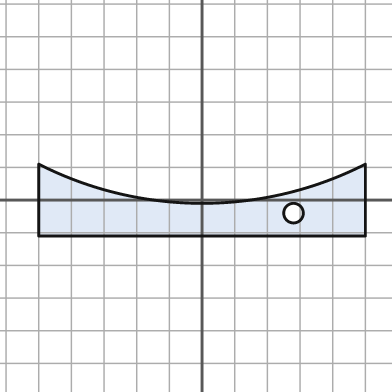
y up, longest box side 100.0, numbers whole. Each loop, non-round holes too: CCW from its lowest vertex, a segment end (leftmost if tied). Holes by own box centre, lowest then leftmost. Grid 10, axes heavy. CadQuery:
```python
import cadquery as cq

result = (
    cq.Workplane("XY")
    .moveTo(-50.0, -11.0)
    .lineTo(50.0, -11.0)
    .lineTo(50.0, 11.0)
    .threePointArc((0.0, -1.0), (-50.0, 11.0))
    .close()
    .moveTo(28.0, -4.0)
    .circle(3.0)
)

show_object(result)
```